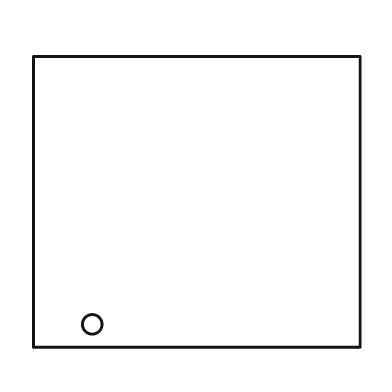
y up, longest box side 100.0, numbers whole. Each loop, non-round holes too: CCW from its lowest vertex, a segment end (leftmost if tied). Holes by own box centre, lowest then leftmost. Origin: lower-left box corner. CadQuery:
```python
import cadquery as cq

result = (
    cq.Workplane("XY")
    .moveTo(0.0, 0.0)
    .lineTo(100.0, 0.0)
    .lineTo(100.0, 89.0)
    .lineTo(0.0, 89.0)
    .close()
    .moveTo(18.0, 7.0)
    .circle(3.0)
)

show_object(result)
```